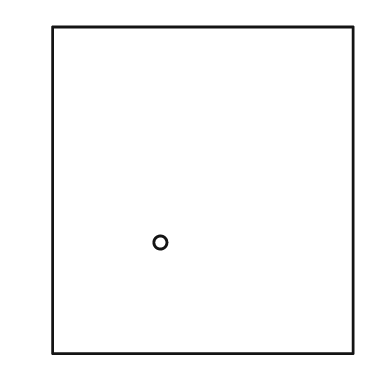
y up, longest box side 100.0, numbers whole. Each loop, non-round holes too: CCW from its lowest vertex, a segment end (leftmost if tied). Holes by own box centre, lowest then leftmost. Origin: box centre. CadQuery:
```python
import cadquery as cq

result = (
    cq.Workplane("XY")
    .moveTo(-46.0, -50.0)
    .lineTo(46.0, -50.0)
    .lineTo(46.0, 50.0)
    .lineTo(-46.0, 50.0)
    .close()
    .moveTo(-13.0, -16.0)
    .circle(2.0)
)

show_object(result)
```